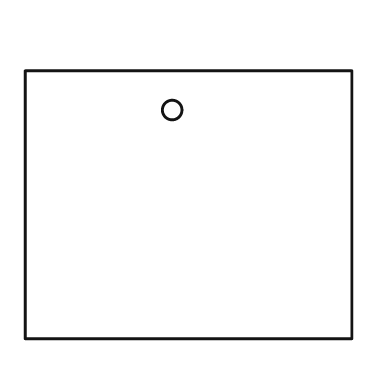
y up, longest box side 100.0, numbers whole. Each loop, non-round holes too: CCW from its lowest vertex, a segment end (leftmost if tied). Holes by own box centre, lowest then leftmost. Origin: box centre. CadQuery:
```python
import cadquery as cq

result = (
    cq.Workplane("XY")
    .moveTo(-50.0, -41.0)
    .lineTo(50.0, -41.0)
    .lineTo(50.0, 41.0)
    .lineTo(-50.0, 41.0)
    .close()
    .moveTo(-5.0, 29.0)
    .circle(3.0)
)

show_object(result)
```